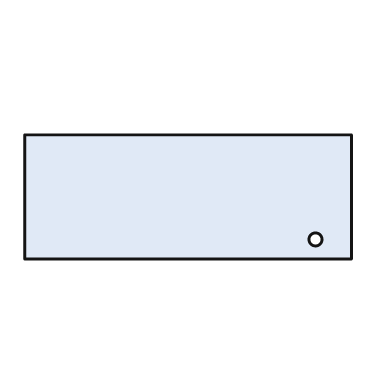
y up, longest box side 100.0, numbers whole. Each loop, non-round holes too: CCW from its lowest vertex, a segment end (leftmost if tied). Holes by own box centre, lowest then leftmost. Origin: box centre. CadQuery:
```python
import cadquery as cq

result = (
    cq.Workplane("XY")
    .moveTo(-50.0, -19.0)
    .lineTo(50.0, -19.0)
    .lineTo(50.0, 19.0)
    .lineTo(-50.0, 19.0)
    .close()
    .moveTo(39.0, -13.0)
    .circle(2.0)
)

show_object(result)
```